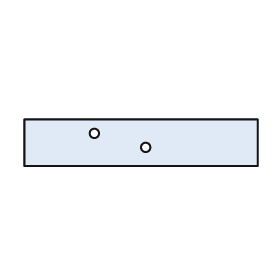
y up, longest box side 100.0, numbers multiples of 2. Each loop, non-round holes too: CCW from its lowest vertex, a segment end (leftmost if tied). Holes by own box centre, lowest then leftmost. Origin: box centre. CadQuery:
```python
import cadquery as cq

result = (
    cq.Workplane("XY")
    .moveTo(-50.0, -10.0)
    .lineTo(50.0, -10.0)
    .lineTo(50.0, 10.0)
    .lineTo(-50.0, 10.0)
    .close()
    .moveTo(2.0, -2.0)
    .circle(2.0)
    .moveTo(-20.0, 4.0)
    .circle(2.0)
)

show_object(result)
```